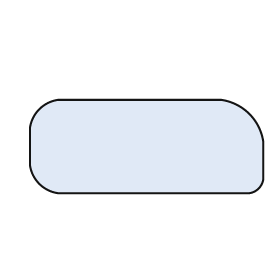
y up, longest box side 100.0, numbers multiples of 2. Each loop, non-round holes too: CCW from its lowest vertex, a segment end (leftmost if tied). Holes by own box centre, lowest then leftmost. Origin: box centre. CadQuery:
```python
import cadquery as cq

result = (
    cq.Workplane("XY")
    .moveTo(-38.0, -20.0)
    .lineTo(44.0, -20.0)
    .threePointArc((48.0, -18.0), (50.0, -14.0))
    .lineTo(50.0, 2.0)
    .threePointArc((44.0, 14.0), (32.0, 20.0))
    .lineTo(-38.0, 20.0)
    .threePointArc((-46.0, 16.0), (-50.0, 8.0))
    .lineTo(-50.0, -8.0)
    .threePointArc((-46.0, -16.0), (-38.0, -20.0))
    .close()
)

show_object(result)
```